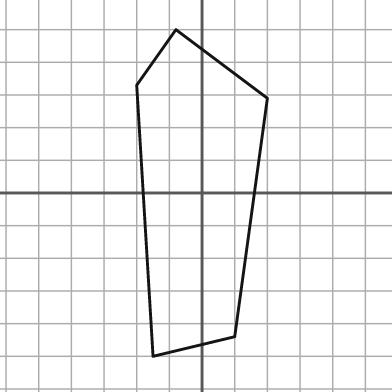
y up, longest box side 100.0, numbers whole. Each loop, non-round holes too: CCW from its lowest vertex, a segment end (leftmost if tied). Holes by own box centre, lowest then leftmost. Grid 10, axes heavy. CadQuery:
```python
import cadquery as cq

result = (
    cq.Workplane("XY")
    .moveTo(-15.0, -50.0)
    .lineTo(10.0, -44.0)
    .lineTo(20.0, 29.0)
    .lineTo(-8.0, 50.0)
    .lineTo(-20.0, 33.0)
    .close()
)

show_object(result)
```